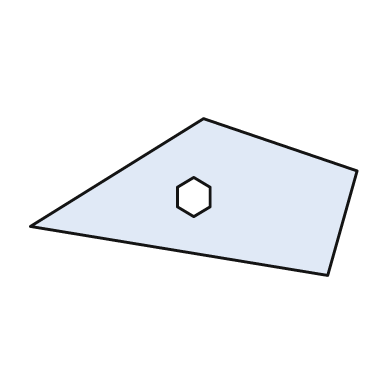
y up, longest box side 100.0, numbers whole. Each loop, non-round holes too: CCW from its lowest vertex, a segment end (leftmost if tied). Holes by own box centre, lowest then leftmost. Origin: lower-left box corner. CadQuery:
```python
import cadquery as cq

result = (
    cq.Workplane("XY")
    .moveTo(91.0, 0.0)
    .lineTo(100.0, 32.0)
    .lineTo(53.0, 48.0)
    .lineTo(0.0, 15.0)
    .close()
    .moveTo(50.0, 18.0)
    .lineTo(55.0, 21.0)
    .lineTo(55.0, 27.0)
    .lineTo(50.0, 30.0)
    .lineTo(45.0, 27.0)
    .lineTo(45.0, 21.0)
    .close()
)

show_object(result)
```